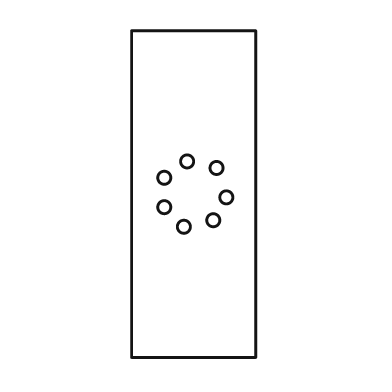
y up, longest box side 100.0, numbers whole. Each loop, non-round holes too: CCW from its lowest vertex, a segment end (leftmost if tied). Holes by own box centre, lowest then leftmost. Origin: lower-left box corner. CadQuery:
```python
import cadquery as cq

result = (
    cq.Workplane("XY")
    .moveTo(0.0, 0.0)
    .lineTo(38.0, 0.0)
    .lineTo(38.0, 100.0)
    .lineTo(0.0, 100.0)
    .close()
    .moveTo(16.0, 40.0)
    .circle(2.0)
    .moveTo(25.0, 42.0)
    .circle(2.0)
    .moveTo(10.0, 46.0)
    .circle(2.0)
    .moveTo(29.0, 49.0)
    .circle(2.0)
    .moveTo(10.0, 55.0)
    .circle(2.0)
    .moveTo(26.0, 58.0)
    .circle(2.0)
    .moveTo(17.0, 60.0)
    .circle(2.0)
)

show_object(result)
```